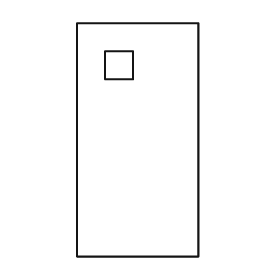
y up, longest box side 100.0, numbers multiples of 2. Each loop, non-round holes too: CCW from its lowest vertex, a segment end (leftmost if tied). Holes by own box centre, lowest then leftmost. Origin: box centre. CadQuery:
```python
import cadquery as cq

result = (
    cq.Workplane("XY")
    .moveTo(-26.0, -50.0)
    .lineTo(26.0, -50.0)
    .lineTo(26.0, 50.0)
    .lineTo(-26.0, 50.0)
    .close()
    .moveTo(-14.0, 26.0)
    .lineTo(-2.0, 26.0)
    .lineTo(-2.0, 38.0)
    .lineTo(-14.0, 38.0)
    .close()
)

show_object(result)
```